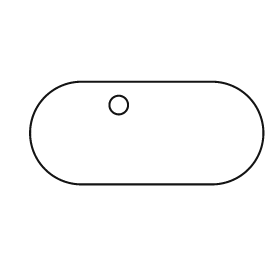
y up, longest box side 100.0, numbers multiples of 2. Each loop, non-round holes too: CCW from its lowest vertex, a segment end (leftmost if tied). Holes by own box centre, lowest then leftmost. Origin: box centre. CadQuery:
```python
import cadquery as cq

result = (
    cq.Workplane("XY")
    .moveTo(-28.0, -22.0)
    .lineTo(28.0, -22.0)
    .threePointArc((50.0, 0.0), (28.0, 22.0))
    .lineTo(-28.0, 22.0)
    .threePointArc((-50.0, 0.0), (-28.0, -22.0))
    .close()
    .moveTo(-12.0, 12.0)
    .circle(4.0)
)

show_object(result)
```